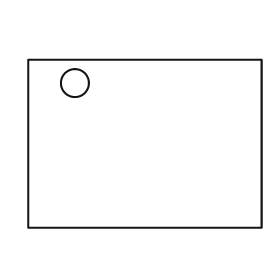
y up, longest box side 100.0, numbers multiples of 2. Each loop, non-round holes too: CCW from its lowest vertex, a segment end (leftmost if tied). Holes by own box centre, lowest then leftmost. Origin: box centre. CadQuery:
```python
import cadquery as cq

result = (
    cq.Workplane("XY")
    .moveTo(-50.0, -36.0)
    .lineTo(50.0, -36.0)
    .lineTo(50.0, 36.0)
    .lineTo(-50.0, 36.0)
    .close()
    .moveTo(-30.0, 26.0)
    .circle(6.0)
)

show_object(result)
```